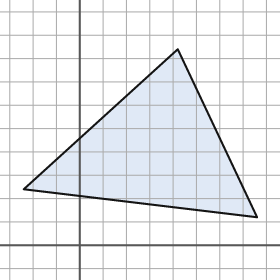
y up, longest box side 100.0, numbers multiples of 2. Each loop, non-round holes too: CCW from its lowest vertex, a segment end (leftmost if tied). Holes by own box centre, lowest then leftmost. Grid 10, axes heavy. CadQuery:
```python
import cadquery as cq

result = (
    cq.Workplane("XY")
    .moveTo(76.0, 12.0)
    .lineTo(42.0, 84.0)
    .lineTo(-24.0, 24.0)
    .close()
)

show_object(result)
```